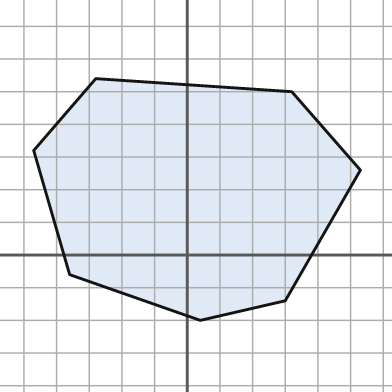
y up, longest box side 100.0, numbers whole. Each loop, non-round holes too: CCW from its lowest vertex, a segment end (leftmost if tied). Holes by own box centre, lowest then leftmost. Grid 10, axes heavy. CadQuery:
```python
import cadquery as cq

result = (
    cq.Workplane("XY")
    .moveTo(4.0, -20.0)
    .lineTo(30.0, -14.0)
    .lineTo(53.0, 26.0)
    .lineTo(32.0, 50.0)
    .lineTo(-28.0, 54.0)
    .lineTo(-47.0, 32.0)
    .lineTo(-36.0, -6.0)
    .close()
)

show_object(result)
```